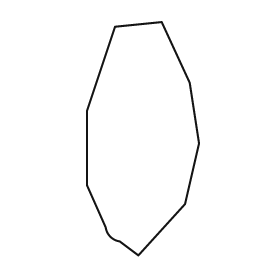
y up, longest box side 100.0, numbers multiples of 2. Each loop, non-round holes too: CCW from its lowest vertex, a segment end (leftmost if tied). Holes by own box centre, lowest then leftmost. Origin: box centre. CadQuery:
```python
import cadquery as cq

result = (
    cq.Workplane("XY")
    .moveTo(-2.0, -50.0)
    .lineTo(18.0, -28.0)
    .lineTo(24.0, -2.0)
    .lineTo(20.0, 24.0)
    .lineTo(8.0, 50.0)
    .lineTo(-12.0, 48.0)
    .lineTo(-24.0, 12.0)
    .lineTo(-24.0, -20.0)
    .lineTo(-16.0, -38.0)
    .threePointArc((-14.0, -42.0), (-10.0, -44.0))
    .close()
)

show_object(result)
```